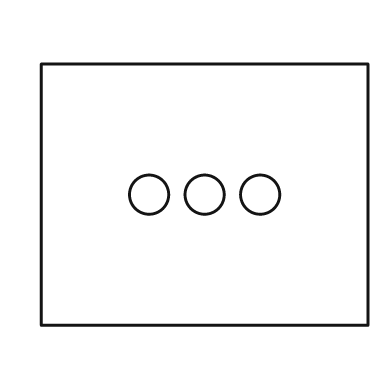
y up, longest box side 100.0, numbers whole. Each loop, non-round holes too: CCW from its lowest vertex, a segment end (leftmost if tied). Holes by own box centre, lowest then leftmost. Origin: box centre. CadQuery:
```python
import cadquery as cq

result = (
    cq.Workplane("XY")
    .moveTo(-50.0, -40.0)
    .lineTo(50.0, -40.0)
    .lineTo(50.0, 40.0)
    .lineTo(-50.0, 40.0)
    .close()
    .moveTo(-17.0, 0.0)
    .circle(6.0)
    .moveTo(0.0, 0.0)
    .circle(6.0)
    .moveTo(17.0, 0.0)
    .circle(6.0)
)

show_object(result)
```